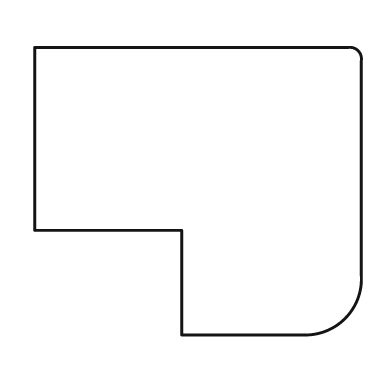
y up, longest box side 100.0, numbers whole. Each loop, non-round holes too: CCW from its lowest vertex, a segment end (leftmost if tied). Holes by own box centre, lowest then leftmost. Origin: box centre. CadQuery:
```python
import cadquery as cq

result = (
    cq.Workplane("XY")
    .moveTo(-5.0, -44.0)
    .lineTo(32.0, -44.0)
    .threePointArc((45.0, -39.0), (50.0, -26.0))
    .lineTo(50.0, 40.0)
    .threePointArc((49.0, 43.0), (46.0, 44.0))
    .lineTo(-50.0, 44.0)
    .lineTo(-50.0, -12.0)
    .lineTo(-5.0, -12.0)
    .close()
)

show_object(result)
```